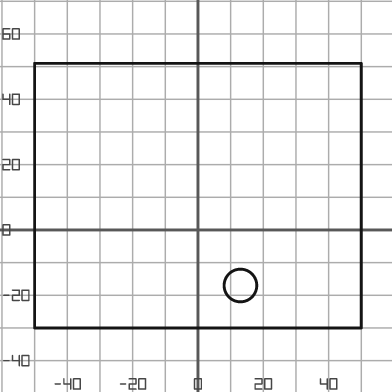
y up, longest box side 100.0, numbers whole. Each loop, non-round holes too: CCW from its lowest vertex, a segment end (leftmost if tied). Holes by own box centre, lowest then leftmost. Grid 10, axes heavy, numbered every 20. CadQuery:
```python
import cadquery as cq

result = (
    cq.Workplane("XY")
    .moveTo(-50.0, -30.0)
    .lineTo(50.0, -30.0)
    .lineTo(50.0, 51.0)
    .lineTo(-50.0, 51.0)
    .close()
    .moveTo(13.0, -17.0)
    .circle(5.0)
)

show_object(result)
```